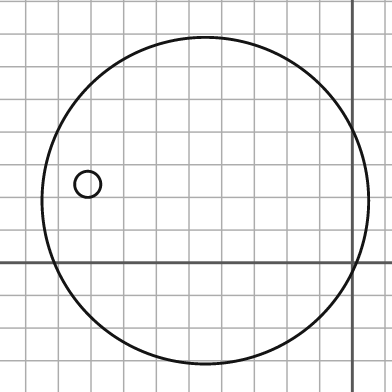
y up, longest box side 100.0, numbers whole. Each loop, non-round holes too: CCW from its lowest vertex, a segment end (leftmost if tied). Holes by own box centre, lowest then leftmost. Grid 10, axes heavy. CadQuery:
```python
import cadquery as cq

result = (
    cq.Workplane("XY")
    .moveTo(-45.0, 19.0)
    .circle(50.0)
    .moveTo(-81.0, 24.0)
    .circle(4.0)
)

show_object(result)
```